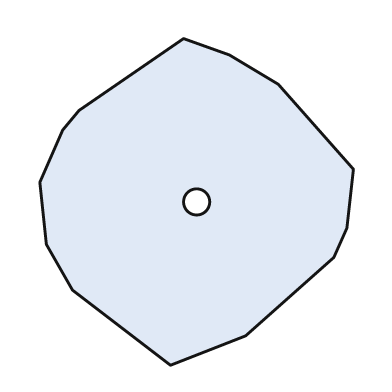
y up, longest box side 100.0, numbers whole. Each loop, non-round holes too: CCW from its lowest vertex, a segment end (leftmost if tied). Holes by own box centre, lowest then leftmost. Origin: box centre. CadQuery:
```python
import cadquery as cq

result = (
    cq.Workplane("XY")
    .moveTo(-8.0, -50.0)
    .lineTo(15.0, -41.0)
    .lineTo(42.0, -17.0)
    .lineTo(46.0, -8.0)
    .lineTo(48.0, 10.0)
    .lineTo(25.0, 36.0)
    .lineTo(10.0, 45.0)
    .lineTo(-4.0, 50.0)
    .lineTo(-36.0, 28.0)
    .lineTo(-41.0, 22.0)
    .lineTo(-48.0, 6.0)
    .lineTo(-46.0, -13.0)
    .lineTo(-38.0, -27.0)
    .close()
    .moveTo(0.0, 0.0)
    .circle(4.0)
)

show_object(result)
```